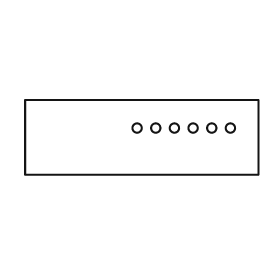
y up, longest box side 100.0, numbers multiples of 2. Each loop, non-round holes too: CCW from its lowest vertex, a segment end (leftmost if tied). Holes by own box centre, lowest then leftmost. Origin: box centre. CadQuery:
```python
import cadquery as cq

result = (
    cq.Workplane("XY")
    .moveTo(-50.0, -16.0)
    .lineTo(50.0, -16.0)
    .lineTo(50.0, 16.0)
    .lineTo(-50.0, 16.0)
    .close()
    .moveTo(-2.0, 4.0)
    .circle(2.0)
    .moveTo(6.0, 4.0)
    .circle(2.0)
    .moveTo(14.0, 4.0)
    .circle(2.0)
    .moveTo(22.0, 4.0)
    .circle(2.0)
    .moveTo(30.0, 4.0)
    .circle(2.0)
    .moveTo(38.0, 4.0)
    .circle(2.0)
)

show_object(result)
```